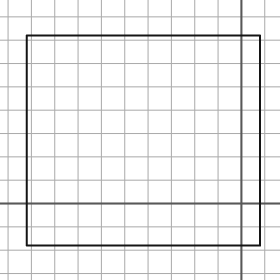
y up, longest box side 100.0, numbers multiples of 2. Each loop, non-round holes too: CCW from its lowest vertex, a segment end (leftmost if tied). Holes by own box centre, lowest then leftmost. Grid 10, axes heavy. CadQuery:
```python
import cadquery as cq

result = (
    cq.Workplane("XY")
    .moveTo(-92.0, -18.0)
    .lineTo(8.0, -18.0)
    .lineTo(8.0, 72.0)
    .lineTo(-92.0, 72.0)
    .close()
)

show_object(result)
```